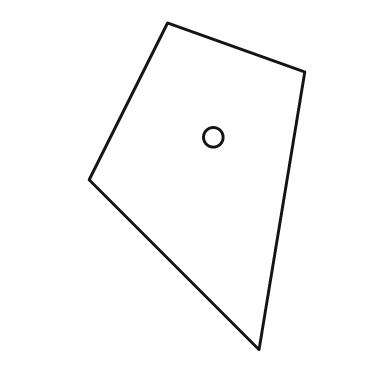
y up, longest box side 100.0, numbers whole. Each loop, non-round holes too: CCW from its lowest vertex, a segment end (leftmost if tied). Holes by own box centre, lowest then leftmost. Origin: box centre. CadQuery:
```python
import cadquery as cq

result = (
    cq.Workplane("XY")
    .moveTo(19.0, -50.0)
    .lineTo(33.0, 35.0)
    .lineTo(-9.0, 50.0)
    .lineTo(-33.0, 2.0)
    .close()
    .moveTo(5.0, 15.0)
    .circle(3.0)
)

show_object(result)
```